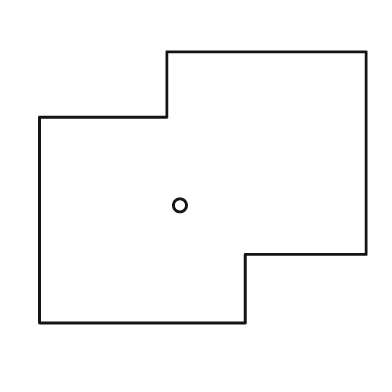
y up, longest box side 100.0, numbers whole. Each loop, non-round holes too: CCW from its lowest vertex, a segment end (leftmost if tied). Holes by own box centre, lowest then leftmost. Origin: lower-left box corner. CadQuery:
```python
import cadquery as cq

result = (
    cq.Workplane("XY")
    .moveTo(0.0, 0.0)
    .lineTo(63.0, 0.0)
    .lineTo(63.0, 21.0)
    .lineTo(100.0, 21.0)
    .lineTo(100.0, 83.0)
    .lineTo(39.0, 83.0)
    .lineTo(39.0, 63.0)
    .lineTo(0.0, 63.0)
    .close()
    .moveTo(43.0, 36.0)
    .circle(2.0)
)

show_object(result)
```